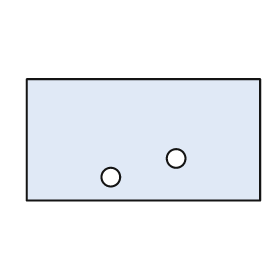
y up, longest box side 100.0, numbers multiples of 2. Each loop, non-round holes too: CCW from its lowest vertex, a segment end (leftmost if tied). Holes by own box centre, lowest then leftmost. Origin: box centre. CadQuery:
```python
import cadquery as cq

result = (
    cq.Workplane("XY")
    .moveTo(-50.0, -26.0)
    .lineTo(50.0, -26.0)
    .lineTo(50.0, 26.0)
    .lineTo(-50.0, 26.0)
    .close()
    .moveTo(-14.0, -16.0)
    .circle(4.0)
    .moveTo(14.0, -8.0)
    .circle(4.0)
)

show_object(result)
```